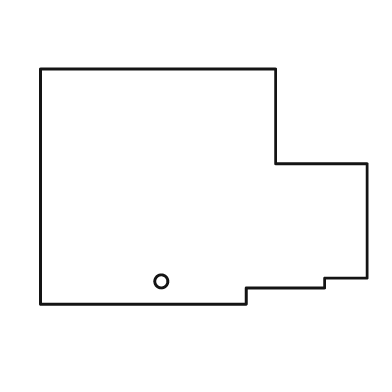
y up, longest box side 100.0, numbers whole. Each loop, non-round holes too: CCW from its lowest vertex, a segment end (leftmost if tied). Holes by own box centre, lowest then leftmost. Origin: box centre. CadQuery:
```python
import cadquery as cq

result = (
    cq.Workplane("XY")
    .moveTo(-50.0, -36.0)
    .lineTo(13.0, -36.0)
    .lineTo(13.0, -31.0)
    .lineTo(37.0, -31.0)
    .lineTo(37.0, -28.0)
    .lineTo(50.0, -28.0)
    .lineTo(50.0, 7.0)
    .lineTo(22.0, 7.0)
    .lineTo(22.0, 36.0)
    .lineTo(-50.0, 36.0)
    .close()
    .moveTo(-13.0, -29.0)
    .circle(2.0)
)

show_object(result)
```